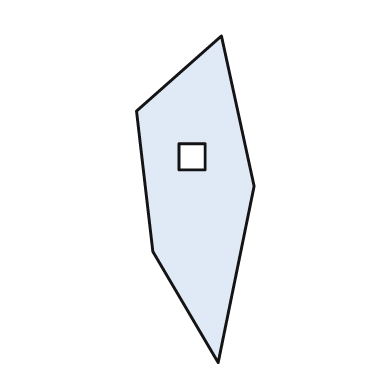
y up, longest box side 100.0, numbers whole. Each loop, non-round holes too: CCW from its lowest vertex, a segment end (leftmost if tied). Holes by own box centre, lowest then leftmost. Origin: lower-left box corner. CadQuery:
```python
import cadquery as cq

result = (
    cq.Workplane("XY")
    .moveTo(25.0, 0.0)
    .lineTo(36.0, 54.0)
    .lineTo(26.0, 100.0)
    .lineTo(0.0, 77.0)
    .lineTo(5.0, 34.0)
    .close()
    .moveTo(13.0, 59.0)
    .lineTo(21.0, 59.0)
    .lineTo(21.0, 67.0)
    .lineTo(13.0, 67.0)
    .close()
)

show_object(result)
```